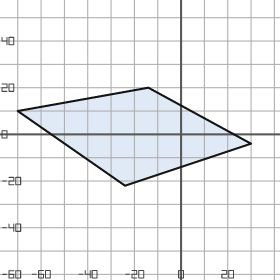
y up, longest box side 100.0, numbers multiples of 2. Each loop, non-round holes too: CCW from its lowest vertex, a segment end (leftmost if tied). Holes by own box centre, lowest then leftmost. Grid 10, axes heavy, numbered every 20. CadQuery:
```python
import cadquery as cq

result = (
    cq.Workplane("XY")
    .moveTo(-24.0, -22.0)
    .lineTo(30.0, -4.0)
    .lineTo(-14.0, 20.0)
    .lineTo(-70.0, 10.0)
    .close()
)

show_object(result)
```